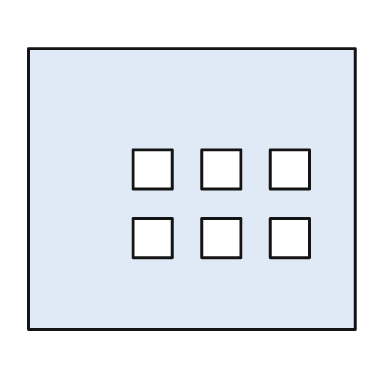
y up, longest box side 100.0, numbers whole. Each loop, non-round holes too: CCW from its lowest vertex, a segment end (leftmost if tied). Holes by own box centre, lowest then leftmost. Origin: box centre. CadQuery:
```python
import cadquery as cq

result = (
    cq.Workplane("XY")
    .moveTo(-50.0, -43.0)
    .lineTo(50.0, -43.0)
    .lineTo(50.0, 43.0)
    .lineTo(-50.0, 43.0)
    .close()
    .moveTo(-18.0, -21.0)
    .lineTo(-6.0, -21.0)
    .lineTo(-6.0, -9.0)
    .lineTo(-18.0, -9.0)
    .close()
    .moveTo(3.0, -21.0)
    .lineTo(15.0, -21.0)
    .lineTo(15.0, -9.0)
    .lineTo(3.0, -9.0)
    .close()
    .moveTo(24.0, -21.0)
    .lineTo(36.0, -21.0)
    .lineTo(36.0, -9.0)
    .lineTo(24.0, -9.0)
    .close()
    .moveTo(-18.0, 0.0)
    .lineTo(-6.0, 0.0)
    .lineTo(-6.0, 12.0)
    .lineTo(-18.0, 12.0)
    .close()
    .moveTo(3.0, 0.0)
    .lineTo(15.0, 0.0)
    .lineTo(15.0, 12.0)
    .lineTo(3.0, 12.0)
    .close()
    .moveTo(24.0, 0.0)
    .lineTo(36.0, 0.0)
    .lineTo(36.0, 12.0)
    .lineTo(24.0, 12.0)
    .close()
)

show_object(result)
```